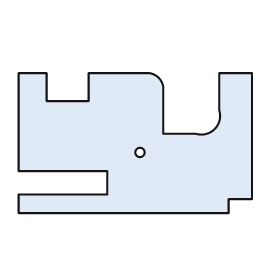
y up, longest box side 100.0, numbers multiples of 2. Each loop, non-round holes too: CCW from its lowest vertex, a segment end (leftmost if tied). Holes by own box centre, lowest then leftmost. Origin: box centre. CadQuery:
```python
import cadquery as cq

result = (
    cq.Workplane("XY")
    .moveTo(-50.0, -30.0)
    .lineTo(40.0, -30.0)
    .lineTo(40.0, -24.0)
    .lineTo(50.0, -24.0)
    .lineTo(50.0, 30.0)
    .lineTo(36.0, 30.0)
    .lineTo(36.0, 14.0)
    .threePointArc((34.0, 6.0), (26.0, 4.0))
    .lineTo(12.0, 4.0)
    .lineTo(12.0, 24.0)
    .threePointArc((10.0, 28.0), (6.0, 30.0))
    .lineTo(-20.0, 30.0)
    .lineTo(-20.0, 18.0)
    .lineTo(-38.0, 18.0)
    .lineTo(-38.0, 30.0)
    .lineTo(-50.0, 30.0)
    .lineTo(-50.0, -12.0)
    .lineTo(-12.0, -12.0)
    .lineTo(-12.0, -22.0)
    .lineTo(-50.0, -22.0)
    .close()
    .moveTo(2.0, -4.0)
    .circle(2.0)
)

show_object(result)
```